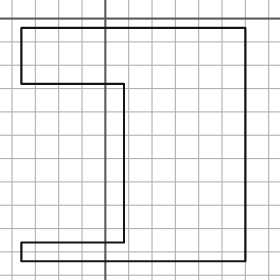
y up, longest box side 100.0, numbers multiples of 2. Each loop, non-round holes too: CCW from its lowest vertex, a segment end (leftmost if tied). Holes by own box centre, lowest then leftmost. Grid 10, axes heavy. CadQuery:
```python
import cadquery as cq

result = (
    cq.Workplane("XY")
    .moveTo(-36.0, -104.0)
    .lineTo(60.0, -104.0)
    .lineTo(60.0, -4.0)
    .lineTo(-36.0, -4.0)
    .lineTo(-36.0, -28.0)
    .lineTo(8.0, -28.0)
    .lineTo(8.0, -96.0)
    .lineTo(-36.0, -96.0)
    .close()
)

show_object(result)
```